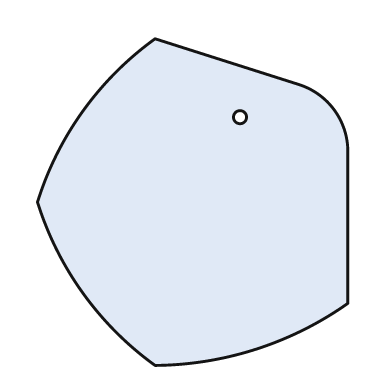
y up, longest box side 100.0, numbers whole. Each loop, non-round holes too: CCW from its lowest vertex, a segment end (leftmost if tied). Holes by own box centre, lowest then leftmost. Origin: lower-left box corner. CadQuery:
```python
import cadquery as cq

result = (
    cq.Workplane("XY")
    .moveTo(36.0, 0.0)
    .threePointArc((67.0, 5.0), (95.0, 19.0))
    .lineTo(95.0, 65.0)
    .threePointArc((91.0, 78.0), (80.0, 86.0))
    .lineTo(36.0, 100.0)
    .threePointArc((14.0, 78.0), (0.0, 50.0))
    .threePointArc((14.0, 22.0), (36.0, 0.0))
    .close()
    .moveTo(62.0, 76.0)
    .circle(2.0)
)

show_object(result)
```